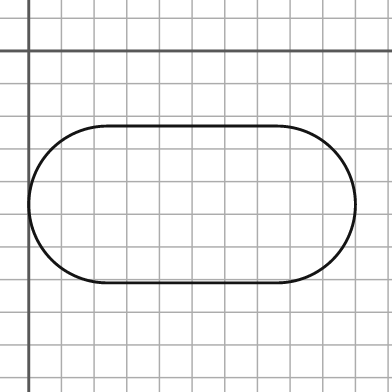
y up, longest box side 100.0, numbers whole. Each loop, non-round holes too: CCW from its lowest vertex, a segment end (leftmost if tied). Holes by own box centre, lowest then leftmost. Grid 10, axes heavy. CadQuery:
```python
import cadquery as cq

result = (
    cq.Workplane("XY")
    .moveTo(24.0, -71.0)
    .lineTo(76.0, -71.0)
    .threePointArc((100.0, -47.0), (76.0, -23.0))
    .lineTo(24.0, -23.0)
    .threePointArc((0.0, -47.0), (24.0, -71.0))
    .close()
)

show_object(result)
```